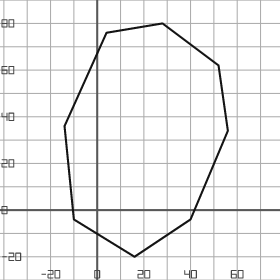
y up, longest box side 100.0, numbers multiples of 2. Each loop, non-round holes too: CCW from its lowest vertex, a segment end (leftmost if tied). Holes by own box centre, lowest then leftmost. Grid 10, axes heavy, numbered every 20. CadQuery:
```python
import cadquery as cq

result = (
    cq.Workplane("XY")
    .moveTo(16.0, -20.0)
    .lineTo(40.0, -4.0)
    .lineTo(56.0, 34.0)
    .lineTo(52.0, 62.0)
    .lineTo(28.0, 80.0)
    .lineTo(4.0, 76.0)
    .lineTo(-14.0, 36.0)
    .lineTo(-10.0, -4.0)
    .close()
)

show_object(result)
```